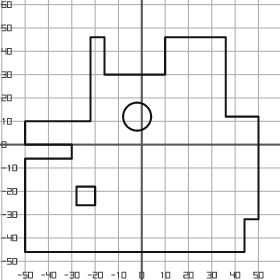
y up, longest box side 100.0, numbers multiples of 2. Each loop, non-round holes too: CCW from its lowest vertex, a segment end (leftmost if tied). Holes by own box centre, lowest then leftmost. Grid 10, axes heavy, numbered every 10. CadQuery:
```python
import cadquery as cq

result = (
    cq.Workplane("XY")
    .moveTo(-50.0, -46.0)
    .lineTo(44.0, -46.0)
    .lineTo(44.0, -32.0)
    .lineTo(50.0, -32.0)
    .lineTo(50.0, 12.0)
    .lineTo(36.0, 12.0)
    .lineTo(36.0, 46.0)
    .lineTo(10.0, 46.0)
    .lineTo(10.0, 30.0)
    .lineTo(-16.0, 30.0)
    .lineTo(-16.0, 46.0)
    .lineTo(-22.0, 46.0)
    .lineTo(-22.0, 10.0)
    .lineTo(-50.0, 10.0)
    .lineTo(-50.0, 0.0)
    .lineTo(-30.0, 0.0)
    .lineTo(-30.0, -6.0)
    .lineTo(-50.0, -6.0)
    .close()
    .moveTo(-28.0, -26.0)
    .lineTo(-20.0, -26.0)
    .lineTo(-20.0, -18.0)
    .lineTo(-28.0, -18.0)
    .close()
    .moveTo(-2.0, 12.0)
    .circle(6.0)
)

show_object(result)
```